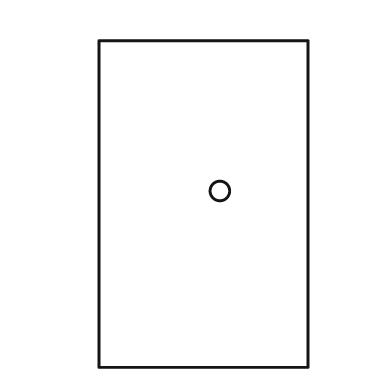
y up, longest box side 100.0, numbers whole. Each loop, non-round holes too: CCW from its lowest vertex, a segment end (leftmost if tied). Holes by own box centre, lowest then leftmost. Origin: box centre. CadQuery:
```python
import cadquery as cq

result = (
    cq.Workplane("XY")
    .moveTo(-32.0, -50.0)
    .lineTo(32.0, -50.0)
    .lineTo(32.0, 50.0)
    .lineTo(-32.0, 50.0)
    .close()
    .moveTo(5.0, 4.0)
    .circle(3.0)
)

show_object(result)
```